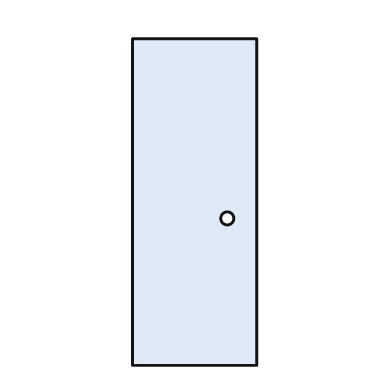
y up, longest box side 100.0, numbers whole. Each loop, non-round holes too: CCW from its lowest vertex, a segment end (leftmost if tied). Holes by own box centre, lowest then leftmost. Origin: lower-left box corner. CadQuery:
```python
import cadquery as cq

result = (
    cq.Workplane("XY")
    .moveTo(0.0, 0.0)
    .lineTo(38.0, 0.0)
    .lineTo(38.0, 100.0)
    .lineTo(0.0, 100.0)
    .close()
    .moveTo(29.0, 45.0)
    .circle(2.0)
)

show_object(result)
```